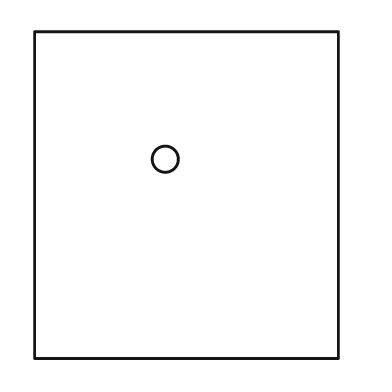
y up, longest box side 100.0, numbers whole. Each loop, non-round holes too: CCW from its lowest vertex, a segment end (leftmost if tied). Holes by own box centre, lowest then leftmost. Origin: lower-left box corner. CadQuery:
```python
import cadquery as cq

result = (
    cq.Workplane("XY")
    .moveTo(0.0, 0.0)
    .lineTo(93.0, 0.0)
    .lineTo(93.0, 100.0)
    .lineTo(0.0, 100.0)
    .close()
    .moveTo(40.0, 61.0)
    .circle(4.0)
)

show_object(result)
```